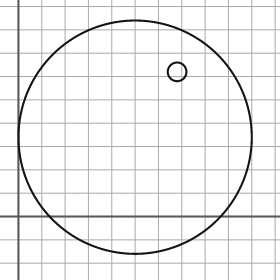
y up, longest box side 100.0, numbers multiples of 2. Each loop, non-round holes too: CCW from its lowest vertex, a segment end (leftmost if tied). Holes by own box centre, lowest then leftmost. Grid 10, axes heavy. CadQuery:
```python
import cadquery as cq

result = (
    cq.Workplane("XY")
    .moveTo(50.0, 34.0)
    .circle(50.0)
    .moveTo(68.0, 62.0)
    .circle(4.0)
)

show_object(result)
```